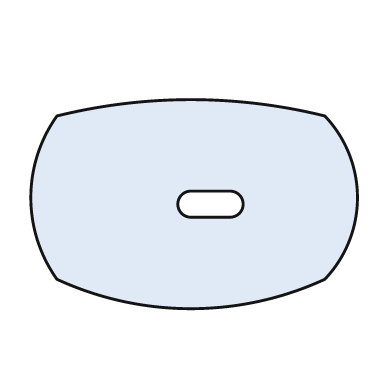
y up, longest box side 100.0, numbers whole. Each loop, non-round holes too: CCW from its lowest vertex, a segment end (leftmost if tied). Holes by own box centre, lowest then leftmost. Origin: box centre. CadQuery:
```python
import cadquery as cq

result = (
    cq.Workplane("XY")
    .moveTo(-42.0, -23.0)
    .threePointArc((-1.0, -32.0), (40.0, -23.0))
    .threePointArc((50.0, 2.0), (40.0, 27.0))
    .threePointArc((-1.0, 32.0), (-42.0, 27.0))
    .threePointArc((-50.0, 2.0), (-42.0, -23.0))
    .close()
    .moveTo(-1.0, -4.0)
    .lineTo(11.0, -4.0)
    .threePointArc((15.0, 0.0), (11.0, 4.0))
    .lineTo(-1.0, 4.0)
    .threePointArc((-5.0, 0.0), (-1.0, -4.0))
    .close()
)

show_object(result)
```